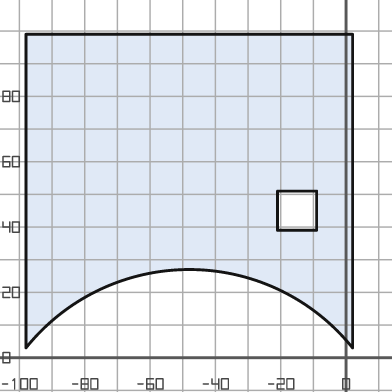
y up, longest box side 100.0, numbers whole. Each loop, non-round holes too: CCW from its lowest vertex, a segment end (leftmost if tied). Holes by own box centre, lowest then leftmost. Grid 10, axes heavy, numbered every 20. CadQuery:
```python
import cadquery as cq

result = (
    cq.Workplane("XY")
    .moveTo(-98.0, 3.0)
    .threePointArc((-48.0, 27.0), (2.0, 3.0))
    .lineTo(2.0, 99.0)
    .lineTo(-98.0, 99.0)
    .close()
    .moveTo(-21.0, 39.0)
    .lineTo(-9.0, 39.0)
    .lineTo(-9.0, 51.0)
    .lineTo(-21.0, 51.0)
    .close()
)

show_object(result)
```